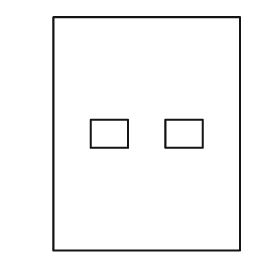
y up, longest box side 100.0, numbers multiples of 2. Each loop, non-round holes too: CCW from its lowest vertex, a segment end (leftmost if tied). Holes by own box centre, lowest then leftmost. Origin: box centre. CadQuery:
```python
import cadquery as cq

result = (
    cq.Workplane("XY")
    .moveTo(-40.0, -50.0)
    .lineTo(40.0, -50.0)
    .lineTo(40.0, 50.0)
    .lineTo(-40.0, 50.0)
    .close()
    .moveTo(-24.0, -6.0)
    .lineTo(-8.0, -6.0)
    .lineTo(-8.0, 6.0)
    .lineTo(-24.0, 6.0)
    .close()
    .moveTo(8.0, -6.0)
    .lineTo(24.0, -6.0)
    .lineTo(24.0, 6.0)
    .lineTo(8.0, 6.0)
    .close()
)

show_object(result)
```